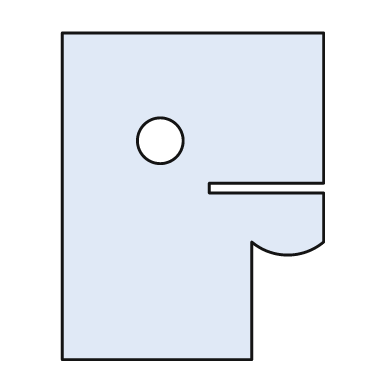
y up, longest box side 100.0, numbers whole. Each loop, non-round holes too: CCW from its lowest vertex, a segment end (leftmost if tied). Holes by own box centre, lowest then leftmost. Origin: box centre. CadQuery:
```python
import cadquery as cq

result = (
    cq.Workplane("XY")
    .moveTo(-40.0, -50.0)
    .lineTo(18.0, -50.0)
    .lineTo(18.0, -14.0)
    .threePointArc((29.0, -18.0), (40.0, -14.0))
    .lineTo(40.0, 1.0)
    .lineTo(5.0, 1.0)
    .lineTo(5.0, 4.0)
    .lineTo(40.0, 4.0)
    .lineTo(40.0, 50.0)
    .lineTo(-40.0, 50.0)
    .close()
    .moveTo(-10.0, 17.0)
    .circle(7.0)
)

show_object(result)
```